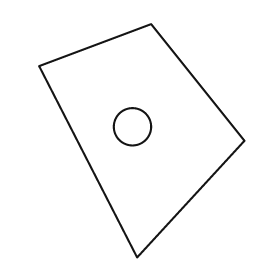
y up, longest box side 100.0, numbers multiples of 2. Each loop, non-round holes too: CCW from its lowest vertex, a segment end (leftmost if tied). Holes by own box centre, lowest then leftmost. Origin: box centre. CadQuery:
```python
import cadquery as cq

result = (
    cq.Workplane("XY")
    .moveTo(-2.0, -50.0)
    .lineTo(44.0, 0.0)
    .lineTo(4.0, 50.0)
    .lineTo(-44.0, 32.0)
    .close()
    .moveTo(-4.0, 6.0)
    .circle(8.0)
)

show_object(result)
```